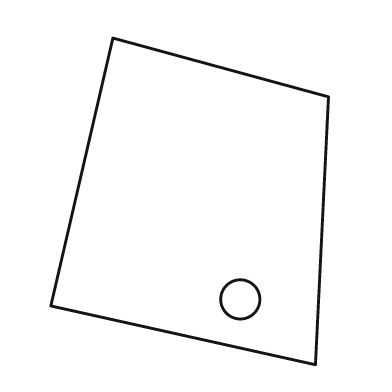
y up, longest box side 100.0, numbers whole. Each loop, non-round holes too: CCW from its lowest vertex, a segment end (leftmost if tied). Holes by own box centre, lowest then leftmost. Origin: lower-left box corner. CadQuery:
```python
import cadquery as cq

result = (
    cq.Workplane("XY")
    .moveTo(81.0, 0.0)
    .lineTo(85.0, 82.0)
    .lineTo(19.0, 100.0)
    .lineTo(0.0, 18.0)
    .close()
    .moveTo(58.0, 20.0)
    .circle(6.0)
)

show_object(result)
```